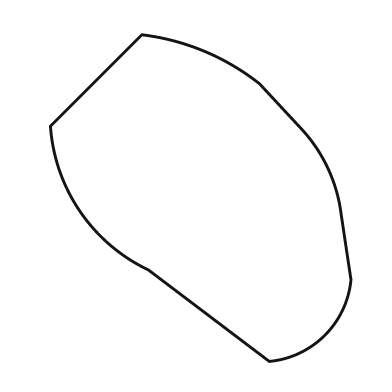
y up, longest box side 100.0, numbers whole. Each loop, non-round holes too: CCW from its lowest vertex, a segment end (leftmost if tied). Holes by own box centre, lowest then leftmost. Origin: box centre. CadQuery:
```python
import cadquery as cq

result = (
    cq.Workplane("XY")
    .moveTo(21.0, -50.0)
    .threePointArc((38.0, -42.0), (46.0, -25.0))
    .lineTo(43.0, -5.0)
    .threePointArc((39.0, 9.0), (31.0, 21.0))
    .lineTo(18.0, 35.0)
    .threePointArc((1.0, 45.0), (-18.0, 50.0))
    .lineTo(-46.0, 22.0)
    .threePointArc((-37.0, -4.0), (-16.0, -22.0))
    .close()
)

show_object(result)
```